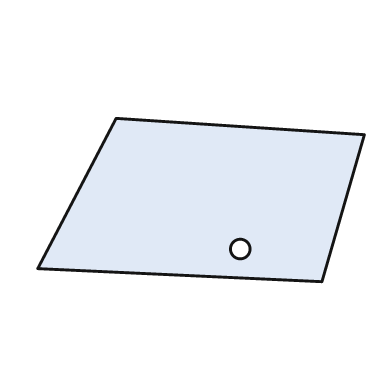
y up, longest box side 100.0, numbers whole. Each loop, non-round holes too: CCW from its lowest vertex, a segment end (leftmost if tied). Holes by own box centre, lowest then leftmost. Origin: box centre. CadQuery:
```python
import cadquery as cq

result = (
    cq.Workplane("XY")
    .moveTo(37.0, -25.0)
    .lineTo(50.0, 20.0)
    .lineTo(-26.0, 25.0)
    .lineTo(-50.0, -21.0)
    .close()
    .moveTo(12.0, -15.0)
    .circle(3.0)
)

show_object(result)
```